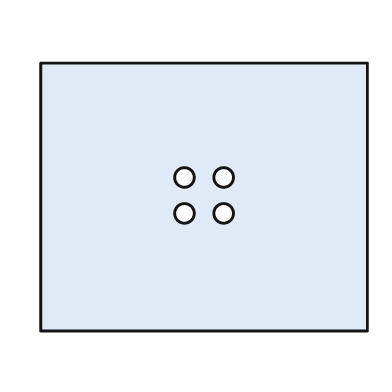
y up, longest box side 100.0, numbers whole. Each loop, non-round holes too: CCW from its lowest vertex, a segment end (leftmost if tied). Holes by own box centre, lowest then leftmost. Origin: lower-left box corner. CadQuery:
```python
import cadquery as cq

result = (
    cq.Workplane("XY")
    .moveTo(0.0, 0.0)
    .lineTo(100.0, 0.0)
    .lineTo(100.0, 82.0)
    .lineTo(0.0, 82.0)
    .close()
    .moveTo(44.0, 36.0)
    .circle(3.0)
    .moveTo(56.0, 36.0)
    .circle(3.0)
    .moveTo(44.0, 47.0)
    .circle(3.0)
    .moveTo(56.0, 47.0)
    .circle(3.0)
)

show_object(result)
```